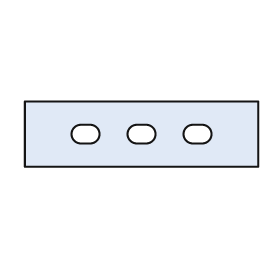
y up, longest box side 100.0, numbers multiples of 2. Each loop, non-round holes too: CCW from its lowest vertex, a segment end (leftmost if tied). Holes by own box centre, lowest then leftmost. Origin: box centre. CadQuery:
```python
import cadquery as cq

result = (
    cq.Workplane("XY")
    .moveTo(-50.0, -14.0)
    .lineTo(50.0, -14.0)
    .lineTo(50.0, 14.0)
    .lineTo(-50.0, 14.0)
    .close()
    .moveTo(-26.0, -4.0)
    .lineTo(-22.0, -4.0)
    .threePointArc((-18.0, 0.0), (-22.0, 4.0))
    .lineTo(-26.0, 4.0)
    .threePointArc((-30.0, 0.0), (-26.0, -4.0))
    .close()
    .moveTo(-2.0, -4.0)
    .lineTo(2.0, -4.0)
    .threePointArc((6.0, 0.0), (2.0, 4.0))
    .lineTo(-2.0, 4.0)
    .threePointArc((-6.0, 0.0), (-2.0, -4.0))
    .close()
    .moveTo(22.0, -4.0)
    .lineTo(26.0, -4.0)
    .threePointArc((30.0, 0.0), (26.0, 4.0))
    .lineTo(22.0, 4.0)
    .threePointArc((18.0, 0.0), (22.0, -4.0))
    .close()
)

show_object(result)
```